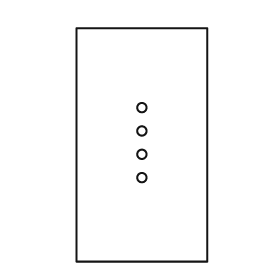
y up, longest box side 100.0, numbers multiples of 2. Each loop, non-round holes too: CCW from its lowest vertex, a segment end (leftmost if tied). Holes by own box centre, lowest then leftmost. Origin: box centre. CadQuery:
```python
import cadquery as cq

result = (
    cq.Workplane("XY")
    .moveTo(-28.0, -50.0)
    .lineTo(28.0, -50.0)
    .lineTo(28.0, 50.0)
    .lineTo(-28.0, 50.0)
    .close()
    .moveTo(0.0, -14.0)
    .circle(2.0)
    .moveTo(0.0, -4.0)
    .circle(2.0)
    .moveTo(0.0, 6.0)
    .circle(2.0)
    .moveTo(0.0, 16.0)
    .circle(2.0)
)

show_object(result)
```